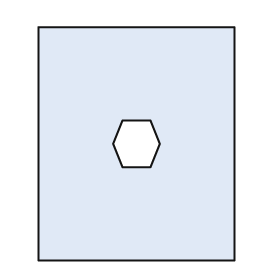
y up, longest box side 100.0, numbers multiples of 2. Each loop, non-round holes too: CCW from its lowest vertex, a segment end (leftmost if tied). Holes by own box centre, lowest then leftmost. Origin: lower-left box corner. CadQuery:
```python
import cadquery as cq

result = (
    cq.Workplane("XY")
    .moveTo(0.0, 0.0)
    .lineTo(84.0, 0.0)
    .lineTo(84.0, 100.0)
    .lineTo(0.0, 100.0)
    .close()
    .moveTo(36.0, 40.0)
    .lineTo(48.0, 40.0)
    .lineTo(52.0, 50.0)
    .lineTo(48.0, 60.0)
    .lineTo(36.0, 60.0)
    .lineTo(32.0, 50.0)
    .close()
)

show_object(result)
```